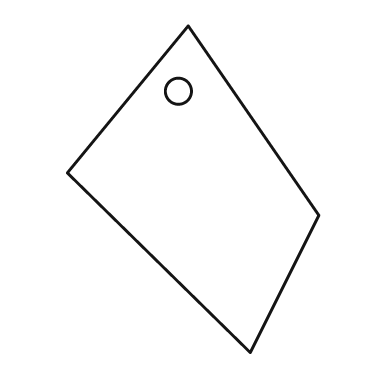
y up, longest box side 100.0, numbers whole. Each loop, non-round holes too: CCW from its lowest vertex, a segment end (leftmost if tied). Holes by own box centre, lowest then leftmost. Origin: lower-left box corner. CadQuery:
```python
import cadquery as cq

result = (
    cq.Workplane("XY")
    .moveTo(56.0, 0.0)
    .lineTo(77.0, 42.0)
    .lineTo(37.0, 100.0)
    .lineTo(0.0, 55.0)
    .close()
    .moveTo(34.0, 80.0)
    .circle(4.0)
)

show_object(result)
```